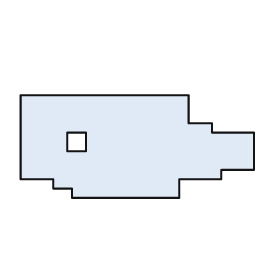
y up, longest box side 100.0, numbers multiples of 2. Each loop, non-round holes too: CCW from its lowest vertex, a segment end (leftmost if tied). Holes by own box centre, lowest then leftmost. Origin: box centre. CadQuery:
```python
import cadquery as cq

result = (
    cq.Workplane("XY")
    .moveTo(-28.0, -22.0)
    .lineTo(18.0, -22.0)
    .lineTo(18.0, -14.0)
    .lineTo(36.0, -14.0)
    .lineTo(36.0, -10.0)
    .lineTo(50.0, -10.0)
    .lineTo(50.0, 6.0)
    .lineTo(32.0, 6.0)
    .lineTo(32.0, 10.0)
    .lineTo(22.0, 10.0)
    .lineTo(22.0, 22.0)
    .lineTo(-50.0, 22.0)
    .lineTo(-50.0, -14.0)
    .lineTo(-36.0, -14.0)
    .lineTo(-36.0, -18.0)
    .lineTo(-28.0, -18.0)
    .close()
    .moveTo(-30.0, -2.0)
    .lineTo(-22.0, -2.0)
    .lineTo(-22.0, 6.0)
    .lineTo(-30.0, 6.0)
    .close()
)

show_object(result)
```